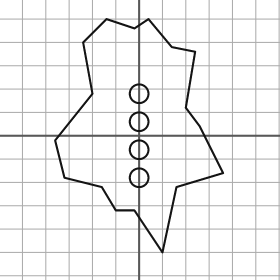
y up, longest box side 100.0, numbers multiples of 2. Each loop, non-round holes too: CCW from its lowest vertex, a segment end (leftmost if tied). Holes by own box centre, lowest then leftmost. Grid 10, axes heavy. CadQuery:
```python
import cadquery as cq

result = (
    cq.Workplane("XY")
    .moveTo(10.0, -50.0)
    .lineTo(16.0, -22.0)
    .lineTo(36.0, -16.0)
    .lineTo(26.0, 4.0)
    .lineTo(20.0, 12.0)
    .lineTo(24.0, 36.0)
    .lineTo(14.0, 38.0)
    .lineTo(4.0, 50.0)
    .lineTo(-2.0, 46.0)
    .lineTo(-14.0, 50.0)
    .lineTo(-24.0, 40.0)
    .lineTo(-20.0, 18.0)
    .lineTo(-36.0, -2.0)
    .lineTo(-32.0, -18.0)
    .lineTo(-16.0, -22.0)
    .lineTo(-10.0, -32.0)
    .lineTo(-2.0, -32.0)
    .close()
    .moveTo(0.0, -18.0)
    .circle(4.0)
    .moveTo(0.0, -6.0)
    .circle(4.0)
    .moveTo(0.0, 6.0)
    .circle(4.0)
    .moveTo(0.0, 18.0)
    .circle(4.0)
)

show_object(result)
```